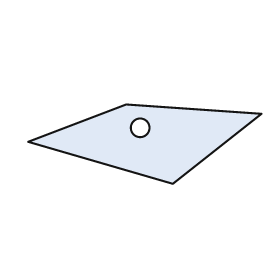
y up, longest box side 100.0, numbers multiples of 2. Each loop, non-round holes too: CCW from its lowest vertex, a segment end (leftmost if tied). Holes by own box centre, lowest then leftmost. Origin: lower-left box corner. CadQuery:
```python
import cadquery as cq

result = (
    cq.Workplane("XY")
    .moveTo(62.0, 0.0)
    .lineTo(100.0, 30.0)
    .lineTo(42.0, 34.0)
    .lineTo(0.0, 18.0)
    .close()
    .moveTo(48.0, 24.0)
    .circle(4.0)
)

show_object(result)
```